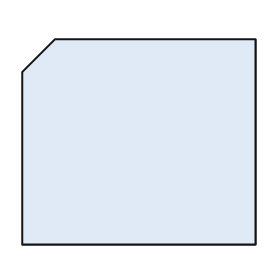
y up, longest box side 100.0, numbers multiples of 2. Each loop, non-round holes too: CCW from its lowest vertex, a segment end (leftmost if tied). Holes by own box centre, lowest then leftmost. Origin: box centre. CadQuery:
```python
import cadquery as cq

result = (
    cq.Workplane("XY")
    .moveTo(-50.0, -44.0)
    .lineTo(50.0, -44.0)
    .lineTo(50.0, 44.0)
    .lineTo(-36.0, 44.0)
    .lineTo(-50.0, 30.0)
    .close()
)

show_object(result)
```